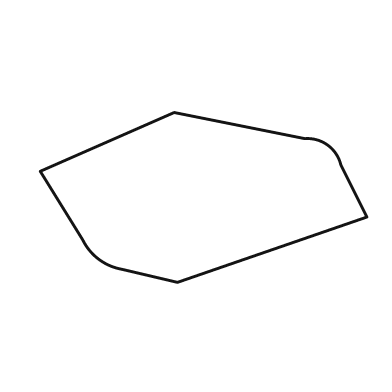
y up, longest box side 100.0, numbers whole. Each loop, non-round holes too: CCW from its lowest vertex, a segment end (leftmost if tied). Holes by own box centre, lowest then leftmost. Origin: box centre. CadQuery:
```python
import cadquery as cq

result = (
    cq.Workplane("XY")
    .moveTo(-8.0, -26.0)
    .lineTo(50.0, -6.0)
    .lineTo(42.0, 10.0)
    .threePointArc((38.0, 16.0), (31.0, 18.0))
    .lineTo(-9.0, 26.0)
    .lineTo(-50.0, 8.0)
    .lineTo(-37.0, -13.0)
    .threePointArc((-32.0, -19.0), (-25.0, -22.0))
    .close()
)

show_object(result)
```